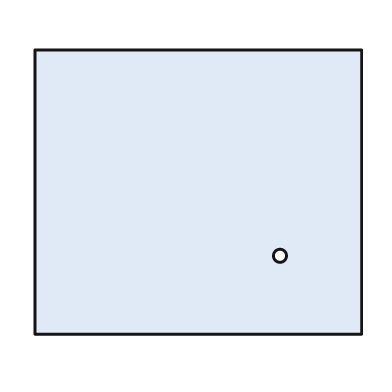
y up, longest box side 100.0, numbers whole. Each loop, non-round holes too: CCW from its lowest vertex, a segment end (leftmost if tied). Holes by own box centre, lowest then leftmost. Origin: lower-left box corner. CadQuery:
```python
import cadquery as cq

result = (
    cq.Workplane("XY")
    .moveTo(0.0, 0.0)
    .lineTo(100.0, 0.0)
    .lineTo(100.0, 87.0)
    .lineTo(0.0, 87.0)
    .close()
    .moveTo(75.0, 24.0)
    .circle(2.0)
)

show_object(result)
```